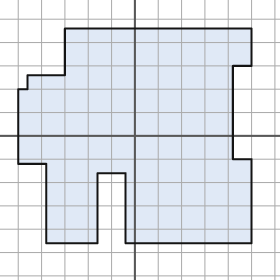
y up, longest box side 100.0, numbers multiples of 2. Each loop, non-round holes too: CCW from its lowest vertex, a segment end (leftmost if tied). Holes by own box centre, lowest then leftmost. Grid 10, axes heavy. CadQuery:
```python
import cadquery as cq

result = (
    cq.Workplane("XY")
    .moveTo(-38.0, -46.0)
    .lineTo(-16.0, -46.0)
    .lineTo(-16.0, -16.0)
    .lineTo(-4.0, -16.0)
    .lineTo(-4.0, -46.0)
    .lineTo(50.0, -46.0)
    .lineTo(50.0, -10.0)
    .lineTo(42.0, -10.0)
    .lineTo(42.0, 30.0)
    .lineTo(50.0, 30.0)
    .lineTo(50.0, 46.0)
    .lineTo(-30.0, 46.0)
    .lineTo(-30.0, 26.0)
    .lineTo(-46.0, 26.0)
    .lineTo(-46.0, 20.0)
    .lineTo(-50.0, 20.0)
    .lineTo(-50.0, -12.0)
    .lineTo(-38.0, -12.0)
    .close()
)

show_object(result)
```